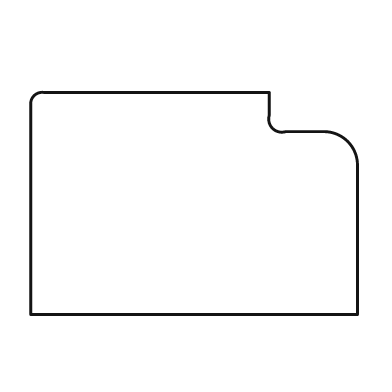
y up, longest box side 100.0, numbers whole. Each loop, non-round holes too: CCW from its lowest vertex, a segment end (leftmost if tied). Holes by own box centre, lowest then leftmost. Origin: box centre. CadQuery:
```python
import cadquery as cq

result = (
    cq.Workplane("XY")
    .moveTo(-50.0, -34.0)
    .lineTo(50.0, -34.0)
    .lineTo(50.0, 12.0)
    .threePointArc((47.0, 19.0), (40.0, 22.0))
    .lineTo(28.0, 22.0)
    .threePointArc((24.0, 23.0), (23.0, 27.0))
    .lineTo(23.0, 34.0)
    .lineTo(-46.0, 34.0)
    .threePointArc((-49.0, 33.0), (-50.0, 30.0))
    .close()
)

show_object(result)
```